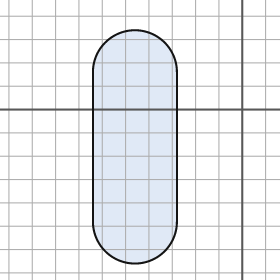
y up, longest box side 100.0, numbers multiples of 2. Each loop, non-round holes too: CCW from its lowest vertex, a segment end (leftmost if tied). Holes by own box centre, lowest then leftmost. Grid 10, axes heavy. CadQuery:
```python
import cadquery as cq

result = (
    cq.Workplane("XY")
    .moveTo(-64.0, -48.0)
    .threePointArc((-46.0, -66.0), (-28.0, -48.0))
    .lineTo(-28.0, 16.0)
    .threePointArc((-46.0, 34.0), (-64.0, 16.0))
    .close()
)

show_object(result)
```